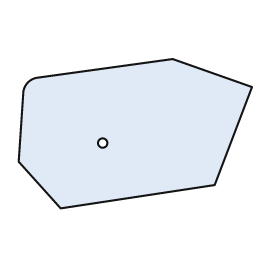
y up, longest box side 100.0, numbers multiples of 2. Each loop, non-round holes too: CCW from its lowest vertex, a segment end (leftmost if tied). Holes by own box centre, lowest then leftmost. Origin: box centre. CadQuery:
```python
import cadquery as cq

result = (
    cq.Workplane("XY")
    .moveTo(-32.0, -32.0)
    .lineTo(34.0, -22.0)
    .lineTo(50.0, 20.0)
    .lineTo(16.0, 32.0)
    .lineTo(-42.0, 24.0)
    .threePointArc((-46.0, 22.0), (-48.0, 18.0))
    .lineTo(-50.0, -12.0)
    .close()
    .moveTo(-14.0, -4.0)
    .circle(2.0)
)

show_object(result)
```